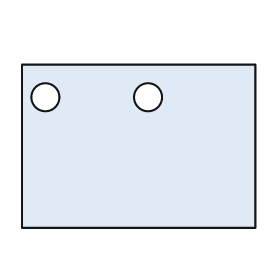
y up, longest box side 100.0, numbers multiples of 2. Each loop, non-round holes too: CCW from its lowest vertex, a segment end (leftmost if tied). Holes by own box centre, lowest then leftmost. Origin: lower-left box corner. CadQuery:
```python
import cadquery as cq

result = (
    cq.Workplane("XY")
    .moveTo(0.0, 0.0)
    .lineTo(100.0, 0.0)
    .lineTo(100.0, 70.0)
    .lineTo(0.0, 70.0)
    .close()
    .moveTo(10.0, 56.0)
    .circle(6.0)
    .moveTo(54.0, 56.0)
    .circle(6.0)
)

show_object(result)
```